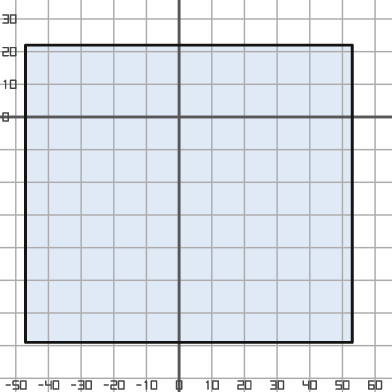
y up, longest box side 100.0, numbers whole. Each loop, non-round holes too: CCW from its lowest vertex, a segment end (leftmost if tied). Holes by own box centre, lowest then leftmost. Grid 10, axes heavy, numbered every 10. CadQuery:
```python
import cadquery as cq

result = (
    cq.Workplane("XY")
    .moveTo(-47.0, -69.0)
    .lineTo(53.0, -69.0)
    .lineTo(53.0, 22.0)
    .lineTo(-47.0, 22.0)
    .close()
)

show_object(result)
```